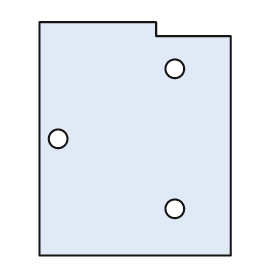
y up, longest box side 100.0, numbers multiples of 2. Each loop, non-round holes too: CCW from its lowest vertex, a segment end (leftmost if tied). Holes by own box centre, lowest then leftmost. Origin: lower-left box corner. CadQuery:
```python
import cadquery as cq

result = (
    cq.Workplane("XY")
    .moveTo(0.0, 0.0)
    .lineTo(82.0, 0.0)
    .lineTo(82.0, 94.0)
    .lineTo(50.0, 94.0)
    .lineTo(50.0, 100.0)
    .lineTo(0.0, 100.0)
    .close()
    .moveTo(58.0, 20.0)
    .circle(4.0)
    .moveTo(8.0, 50.0)
    .circle(4.0)
    .moveTo(58.0, 80.0)
    .circle(4.0)
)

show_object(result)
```